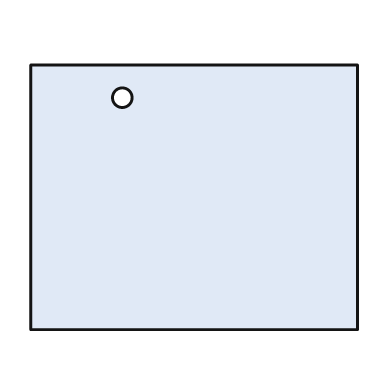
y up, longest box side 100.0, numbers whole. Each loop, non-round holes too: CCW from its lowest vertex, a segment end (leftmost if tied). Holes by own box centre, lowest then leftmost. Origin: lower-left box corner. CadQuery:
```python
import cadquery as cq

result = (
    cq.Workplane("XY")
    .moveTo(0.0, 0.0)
    .lineTo(100.0, 0.0)
    .lineTo(100.0, 81.0)
    .lineTo(0.0, 81.0)
    .close()
    .moveTo(28.0, 71.0)
    .circle(3.0)
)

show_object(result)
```